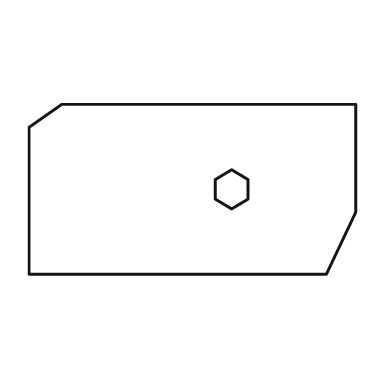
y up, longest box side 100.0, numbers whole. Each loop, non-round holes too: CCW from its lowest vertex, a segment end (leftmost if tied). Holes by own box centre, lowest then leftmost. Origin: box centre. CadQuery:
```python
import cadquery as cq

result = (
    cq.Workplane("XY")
    .moveTo(-50.0, -26.0)
    .lineTo(41.0, -26.0)
    .lineTo(50.0, -7.0)
    .lineTo(50.0, 26.0)
    .lineTo(-40.0, 26.0)
    .lineTo(-50.0, 19.0)
    .close()
    .moveTo(12.0, -6.0)
    .lineTo(17.0, -3.0)
    .lineTo(17.0, 3.0)
    .lineTo(12.0, 6.0)
    .lineTo(7.0, 3.0)
    .lineTo(7.0, -3.0)
    .close()
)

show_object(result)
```